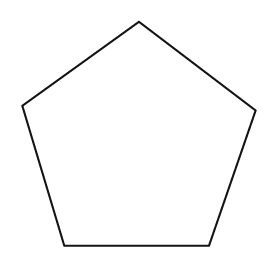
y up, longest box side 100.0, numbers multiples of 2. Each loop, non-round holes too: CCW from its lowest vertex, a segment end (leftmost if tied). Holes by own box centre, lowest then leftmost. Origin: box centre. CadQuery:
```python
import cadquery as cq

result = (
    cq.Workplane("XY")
    .moveTo(-32.0, -48.0)
    .lineTo(30.0, -48.0)
    .lineTo(50.0, 10.0)
    .lineTo(0.0, 48.0)
    .lineTo(-50.0, 12.0)
    .close()
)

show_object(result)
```